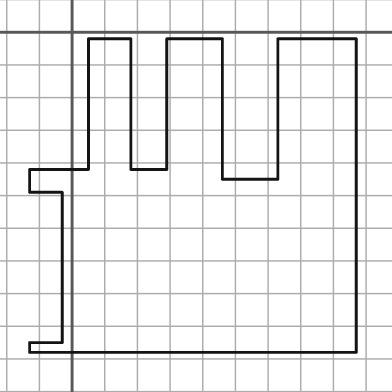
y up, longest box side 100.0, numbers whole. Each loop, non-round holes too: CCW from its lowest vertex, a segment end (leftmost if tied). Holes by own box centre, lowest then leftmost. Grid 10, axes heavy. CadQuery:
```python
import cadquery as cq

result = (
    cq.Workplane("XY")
    .moveTo(-13.0, -98.0)
    .lineTo(87.0, -98.0)
    .lineTo(87.0, -2.0)
    .lineTo(63.0, -2.0)
    .lineTo(63.0, -45.0)
    .lineTo(46.0, -45.0)
    .lineTo(46.0, -2.0)
    .lineTo(29.0, -2.0)
    .lineTo(29.0, -42.0)
    .lineTo(18.0, -42.0)
    .lineTo(18.0, -2.0)
    .lineTo(5.0, -2.0)
    .lineTo(5.0, -42.0)
    .lineTo(-13.0, -42.0)
    .lineTo(-13.0, -49.0)
    .lineTo(-3.0, -49.0)
    .lineTo(-3.0, -95.0)
    .lineTo(-13.0, -95.0)
    .close()
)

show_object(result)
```